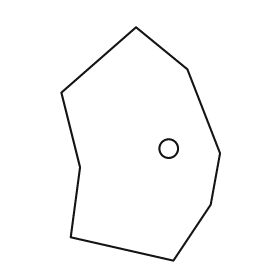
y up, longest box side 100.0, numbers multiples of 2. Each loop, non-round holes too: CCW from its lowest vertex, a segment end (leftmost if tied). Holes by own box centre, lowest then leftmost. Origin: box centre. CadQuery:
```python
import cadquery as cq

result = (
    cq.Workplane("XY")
    .moveTo(14.0, -50.0)
    .lineTo(30.0, -26.0)
    .lineTo(34.0, -4.0)
    .lineTo(20.0, 32.0)
    .lineTo(-2.0, 50.0)
    .lineTo(-34.0, 22.0)
    .lineTo(-26.0, -10.0)
    .lineTo(-30.0, -40.0)
    .close()
    .moveTo(12.0, -2.0)
    .circle(4.0)
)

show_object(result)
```